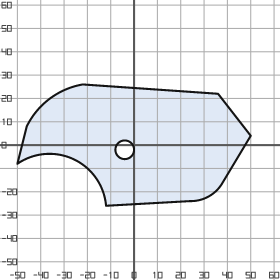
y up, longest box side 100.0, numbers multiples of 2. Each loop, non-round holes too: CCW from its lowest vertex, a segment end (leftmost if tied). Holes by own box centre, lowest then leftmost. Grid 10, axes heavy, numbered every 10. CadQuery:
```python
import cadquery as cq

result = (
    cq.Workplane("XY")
    .moveTo(-12.0, -26.0)
    .lineTo(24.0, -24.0)
    .threePointArc((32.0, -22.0), (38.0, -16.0))
    .lineTo(50.0, 4.0)
    .lineTo(36.0, 22.0)
    .lineTo(-22.0, 26.0)
    .threePointArc((-36.0, 20.0), (-46.0, 8.0))
    .lineTo(-50.0, -8.0)
    .threePointArc((-26.0, -6.0), (-12.0, -26.0))
    .close()
    .moveTo(-4.0, -2.0)
    .circle(4.0)
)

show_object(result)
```